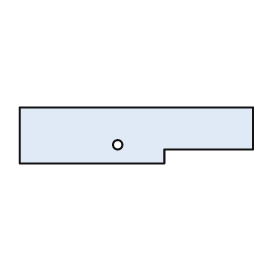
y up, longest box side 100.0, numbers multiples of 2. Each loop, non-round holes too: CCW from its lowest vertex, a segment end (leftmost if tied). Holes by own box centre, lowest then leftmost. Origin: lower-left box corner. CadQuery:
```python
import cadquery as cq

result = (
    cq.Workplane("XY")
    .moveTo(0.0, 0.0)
    .lineTo(62.0, 0.0)
    .lineTo(62.0, 6.0)
    .lineTo(100.0, 6.0)
    .lineTo(100.0, 24.0)
    .lineTo(0.0, 24.0)
    .close()
    .moveTo(42.0, 8.0)
    .circle(2.0)
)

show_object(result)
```